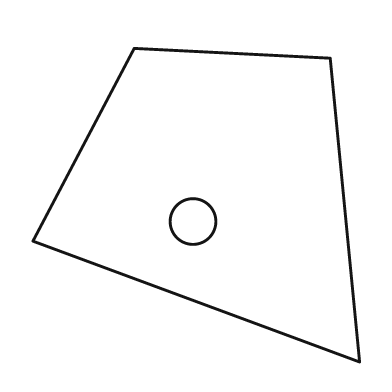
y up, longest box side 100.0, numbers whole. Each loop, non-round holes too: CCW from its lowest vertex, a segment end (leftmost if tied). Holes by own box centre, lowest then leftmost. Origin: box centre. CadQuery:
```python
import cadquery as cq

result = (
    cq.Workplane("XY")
    .moveTo(50.0, -48.0)
    .lineTo(41.0, 45.0)
    .lineTo(-19.0, 48.0)
    .lineTo(-50.0, -11.0)
    .close()
    .moveTo(-1.0, -5.0)
    .circle(7.0)
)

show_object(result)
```